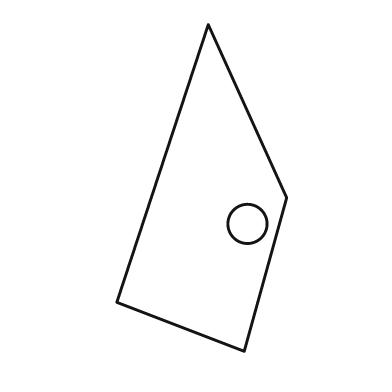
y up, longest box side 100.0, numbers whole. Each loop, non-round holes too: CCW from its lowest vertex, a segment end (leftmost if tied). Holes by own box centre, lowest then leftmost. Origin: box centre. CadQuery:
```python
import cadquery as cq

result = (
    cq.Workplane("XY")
    .moveTo(13.0, -50.0)
    .lineTo(26.0, -3.0)
    .lineTo(2.0, 50.0)
    .lineTo(-26.0, -35.0)
    .close()
    .moveTo(14.0, -11.0)
    .circle(6.0)
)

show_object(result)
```